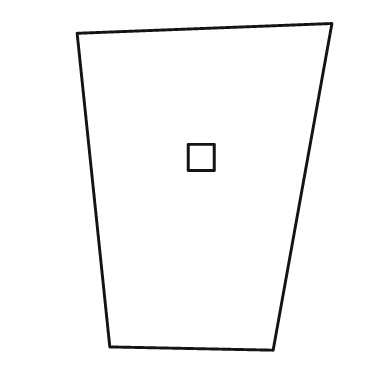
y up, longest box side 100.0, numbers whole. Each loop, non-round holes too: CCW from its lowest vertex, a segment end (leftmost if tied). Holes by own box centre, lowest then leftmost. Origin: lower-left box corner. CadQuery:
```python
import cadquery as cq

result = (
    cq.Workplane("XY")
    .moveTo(60.0, 0.0)
    .lineTo(78.0, 100.0)
    .lineTo(0.0, 97.0)
    .lineTo(10.0, 1.0)
    .close()
    .moveTo(34.0, 55.0)
    .lineTo(42.0, 55.0)
    .lineTo(42.0, 63.0)
    .lineTo(34.0, 63.0)
    .close()
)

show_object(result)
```